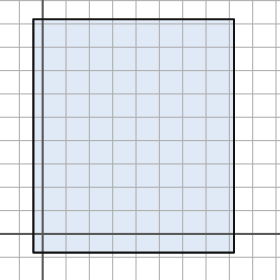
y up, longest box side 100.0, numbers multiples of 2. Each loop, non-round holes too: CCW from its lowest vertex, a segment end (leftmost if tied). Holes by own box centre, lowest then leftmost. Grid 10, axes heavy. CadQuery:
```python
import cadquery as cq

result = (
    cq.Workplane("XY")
    .moveTo(-4.0, -8.0)
    .lineTo(82.0, -8.0)
    .lineTo(82.0, 92.0)
    .lineTo(-4.0, 92.0)
    .close()
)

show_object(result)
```